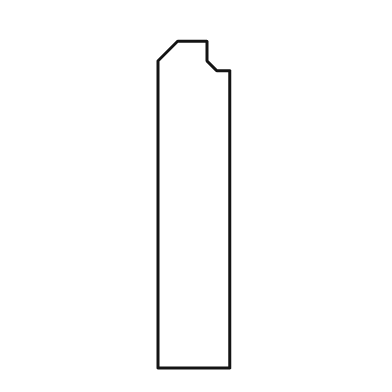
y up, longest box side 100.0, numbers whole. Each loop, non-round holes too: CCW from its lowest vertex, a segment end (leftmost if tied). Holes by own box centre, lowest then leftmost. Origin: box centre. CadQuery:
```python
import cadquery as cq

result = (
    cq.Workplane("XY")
    .moveTo(-11.0, -50.0)
    .lineTo(11.0, -50.0)
    .lineTo(11.0, 41.0)
    .lineTo(7.0, 41.0)
    .lineTo(4.0, 44.0)
    .lineTo(4.0, 50.0)
    .lineTo(-5.0, 50.0)
    .lineTo(-11.0, 44.0)
    .close()
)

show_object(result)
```